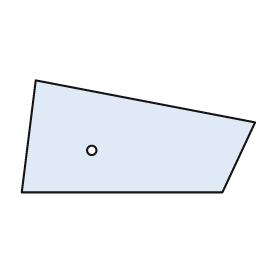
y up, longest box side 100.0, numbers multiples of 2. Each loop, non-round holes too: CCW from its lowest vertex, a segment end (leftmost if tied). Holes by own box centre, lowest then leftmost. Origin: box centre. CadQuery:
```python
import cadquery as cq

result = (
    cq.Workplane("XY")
    .moveTo(-50.0, -24.0)
    .lineTo(36.0, -24.0)
    .lineTo(50.0, 6.0)
    .lineTo(-44.0, 24.0)
    .close()
    .moveTo(-20.0, -6.0)
    .circle(2.0)
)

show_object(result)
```